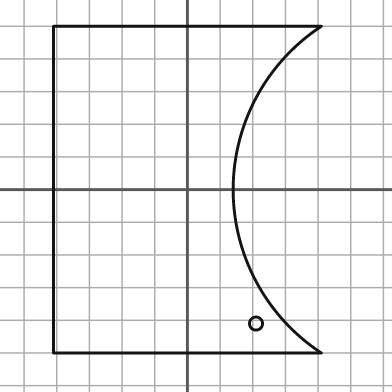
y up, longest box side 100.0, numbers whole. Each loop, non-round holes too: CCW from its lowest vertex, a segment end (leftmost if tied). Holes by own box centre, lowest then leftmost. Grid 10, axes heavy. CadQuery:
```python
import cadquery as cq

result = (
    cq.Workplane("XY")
    .moveTo(-41.0, -50.0)
    .lineTo(41.0, -50.0)
    .threePointArc((14.0, 0.0), (41.0, 50.0))
    .lineTo(-41.0, 50.0)
    .close()
    .moveTo(21.0, -41.0)
    .circle(2.0)
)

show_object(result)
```